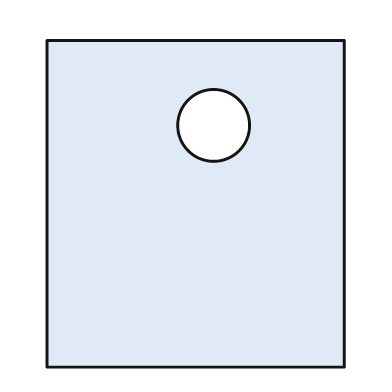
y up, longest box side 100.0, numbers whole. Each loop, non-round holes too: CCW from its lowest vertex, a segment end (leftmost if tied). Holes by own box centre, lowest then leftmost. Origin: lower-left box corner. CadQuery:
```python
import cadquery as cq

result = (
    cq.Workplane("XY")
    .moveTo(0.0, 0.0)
    .lineTo(91.0, 0.0)
    .lineTo(91.0, 100.0)
    .lineTo(0.0, 100.0)
    .close()
    .moveTo(51.0, 74.0)
    .circle(11.0)
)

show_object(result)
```